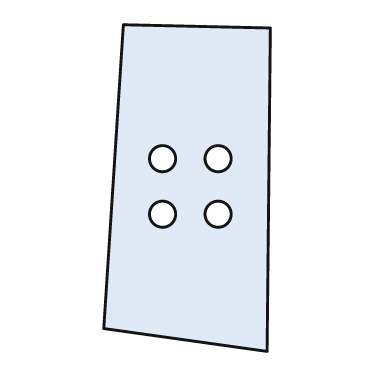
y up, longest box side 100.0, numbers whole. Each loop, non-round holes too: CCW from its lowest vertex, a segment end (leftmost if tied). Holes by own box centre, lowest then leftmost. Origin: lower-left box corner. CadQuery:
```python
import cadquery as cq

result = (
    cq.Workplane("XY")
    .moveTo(50.0, 0.0)
    .lineTo(51.0, 99.0)
    .lineTo(6.0, 100.0)
    .lineTo(0.0, 7.0)
    .close()
    .moveTo(18.0, 42.0)
    .circle(4.0)
    .moveTo(35.0, 42.0)
    .circle(4.0)
    .moveTo(18.0, 59.0)
    .circle(4.0)
    .moveTo(35.0, 59.0)
    .circle(4.0)
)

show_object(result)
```